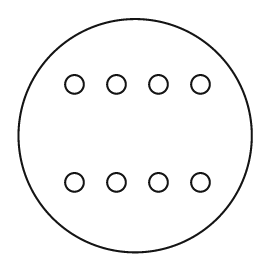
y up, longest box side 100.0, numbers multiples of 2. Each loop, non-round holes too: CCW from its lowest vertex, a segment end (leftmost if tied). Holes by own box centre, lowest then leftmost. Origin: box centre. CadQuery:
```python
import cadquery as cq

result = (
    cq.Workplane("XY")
    .moveTo(0.0, 0.0)
    .circle(50.0)
    .moveTo(-26.0, -20.0)
    .circle(4.0)
    .moveTo(-8.0, -20.0)
    .circle(4.0)
    .moveTo(10.0, -20.0)
    .circle(4.0)
    .moveTo(28.0, -20.0)
    .circle(4.0)
    .moveTo(-26.0, 22.0)
    .circle(4.0)
    .moveTo(-8.0, 22.0)
    .circle(4.0)
    .moveTo(10.0, 22.0)
    .circle(4.0)
    .moveTo(28.0, 22.0)
    .circle(4.0)
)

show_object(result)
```